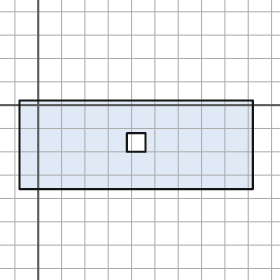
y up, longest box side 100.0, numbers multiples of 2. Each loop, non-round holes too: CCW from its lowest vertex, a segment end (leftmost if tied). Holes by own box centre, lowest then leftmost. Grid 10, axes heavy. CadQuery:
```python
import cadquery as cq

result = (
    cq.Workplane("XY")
    .moveTo(-8.0, -36.0)
    .lineTo(92.0, -36.0)
    .lineTo(92.0, 2.0)
    .lineTo(-8.0, 2.0)
    .close()
    .moveTo(38.0, -20.0)
    .lineTo(46.0, -20.0)
    .lineTo(46.0, -12.0)
    .lineTo(38.0, -12.0)
    .close()
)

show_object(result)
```